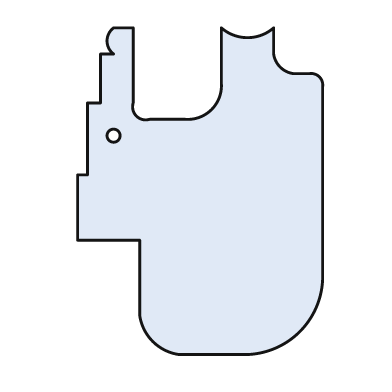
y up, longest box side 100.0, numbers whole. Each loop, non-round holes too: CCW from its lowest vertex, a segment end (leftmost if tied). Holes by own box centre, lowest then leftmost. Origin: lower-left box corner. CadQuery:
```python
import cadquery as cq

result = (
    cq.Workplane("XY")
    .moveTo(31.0, 0.0)
    .lineTo(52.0, 0.0)
    .threePointArc((68.0, 7.0), (75.0, 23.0))
    .lineTo(75.0, 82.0)
    .threePointArc((74.0, 85.0), (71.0, 86.0))
    .lineTo(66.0, 86.0)
    .threePointArc((62.0, 88.0), (60.0, 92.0))
    .lineTo(60.0, 100.0)
    .threePointArc((52.0, 97.0), (44.0, 100.0))
    .lineTo(44.0, 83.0)
    .threePointArc((41.0, 75.0), (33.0, 72.0))
    .lineTo(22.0, 72.0)
    .threePointArc((18.0, 73.0), (17.0, 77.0))
    .lineTo(17.0, 100.0)
    .lineTo(11.0, 100.0)
    .threePointArc((9.0, 96.0), (11.0, 92.0))
    .lineTo(7.0, 92.0)
    .lineTo(7.0, 77.0)
    .lineTo(3.0, 77.0)
    .lineTo(3.0, 55.0)
    .lineTo(0.0, 55.0)
    .lineTo(0.0, 35.0)
    .lineTo(19.0, 35.0)
    .lineTo(19.0, 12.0)
    .threePointArc((23.0, 4.0), (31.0, 0.0))
    .close()
    .moveTo(11.0, 67.0)
    .circle(2.0)
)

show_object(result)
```